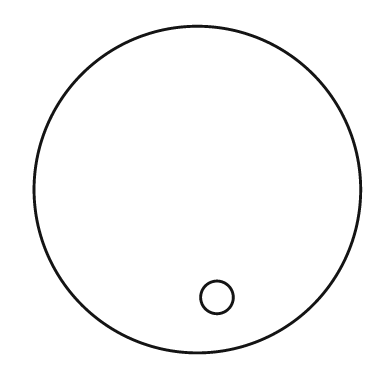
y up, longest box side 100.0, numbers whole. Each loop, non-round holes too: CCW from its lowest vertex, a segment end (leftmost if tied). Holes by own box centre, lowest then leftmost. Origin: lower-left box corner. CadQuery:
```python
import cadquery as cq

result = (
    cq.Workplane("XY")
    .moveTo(50.0, 50.0)
    .circle(50.0)
    .moveTo(56.0, 17.0)
    .circle(5.0)
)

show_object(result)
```